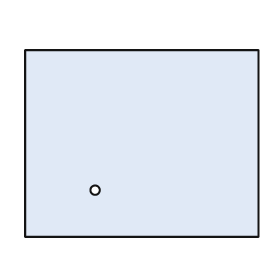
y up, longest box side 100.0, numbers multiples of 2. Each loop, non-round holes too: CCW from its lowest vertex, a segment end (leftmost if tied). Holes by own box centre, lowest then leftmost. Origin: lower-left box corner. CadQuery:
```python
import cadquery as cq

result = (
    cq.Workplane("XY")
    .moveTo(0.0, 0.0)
    .lineTo(100.0, 0.0)
    .lineTo(100.0, 80.0)
    .lineTo(0.0, 80.0)
    .close()
    .moveTo(30.0, 20.0)
    .circle(2.0)
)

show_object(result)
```